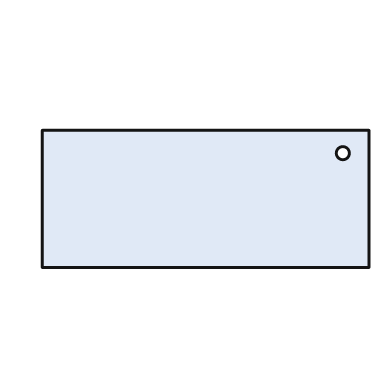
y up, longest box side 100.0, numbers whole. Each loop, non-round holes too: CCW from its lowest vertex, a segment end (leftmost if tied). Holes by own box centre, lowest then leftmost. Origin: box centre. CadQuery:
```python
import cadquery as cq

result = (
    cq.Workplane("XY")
    .moveTo(-50.0, -21.0)
    .lineTo(50.0, -21.0)
    .lineTo(50.0, 21.0)
    .lineTo(-50.0, 21.0)
    .close()
    .moveTo(42.0, 14.0)
    .circle(2.0)
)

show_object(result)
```